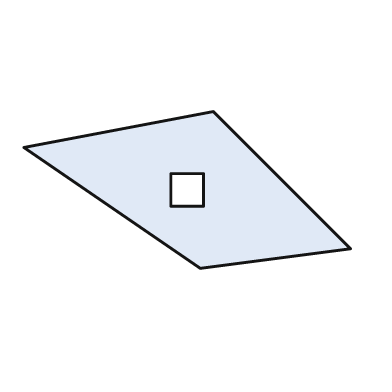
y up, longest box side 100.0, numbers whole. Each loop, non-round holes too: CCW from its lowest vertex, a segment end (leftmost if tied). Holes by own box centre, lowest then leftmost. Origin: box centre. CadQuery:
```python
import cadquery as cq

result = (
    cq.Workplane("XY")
    .moveTo(4.0, -24.0)
    .lineTo(50.0, -18.0)
    .lineTo(8.0, 24.0)
    .lineTo(-50.0, 13.0)
    .close()
    .moveTo(-5.0, -5.0)
    .lineTo(5.0, -5.0)
    .lineTo(5.0, 5.0)
    .lineTo(-5.0, 5.0)
    .close()
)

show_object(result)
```